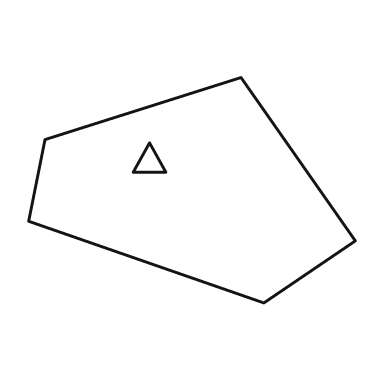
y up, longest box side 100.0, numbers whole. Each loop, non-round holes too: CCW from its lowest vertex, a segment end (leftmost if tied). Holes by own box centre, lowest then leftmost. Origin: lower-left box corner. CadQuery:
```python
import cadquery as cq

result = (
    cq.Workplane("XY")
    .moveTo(72.0, 0.0)
    .lineTo(100.0, 19.0)
    .lineTo(65.0, 69.0)
    .lineTo(5.0, 50.0)
    .lineTo(0.0, 25.0)
    .close()
    .moveTo(32.0, 40.0)
    .lineTo(42.0, 40.0)
    .lineTo(37.0, 49.0)
    .close()
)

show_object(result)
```